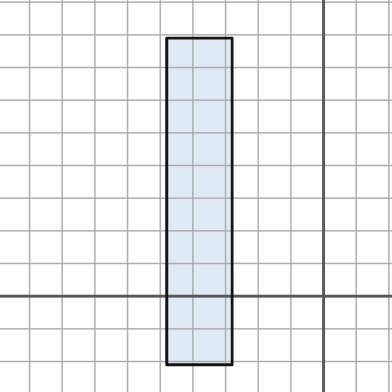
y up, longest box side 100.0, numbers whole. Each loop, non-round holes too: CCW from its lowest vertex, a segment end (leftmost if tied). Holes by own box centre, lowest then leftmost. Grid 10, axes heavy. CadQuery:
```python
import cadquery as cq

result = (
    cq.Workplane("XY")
    .moveTo(-48.0, -21.0)
    .lineTo(-28.0, -21.0)
    .lineTo(-28.0, 79.0)
    .lineTo(-48.0, 79.0)
    .close()
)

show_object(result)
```